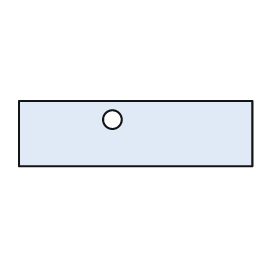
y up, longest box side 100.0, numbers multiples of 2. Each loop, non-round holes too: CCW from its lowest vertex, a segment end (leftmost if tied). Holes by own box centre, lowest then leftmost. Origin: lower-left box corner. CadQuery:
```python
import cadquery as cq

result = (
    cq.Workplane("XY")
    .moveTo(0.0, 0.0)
    .lineTo(100.0, 0.0)
    .lineTo(100.0, 28.0)
    .lineTo(0.0, 28.0)
    .close()
    .moveTo(40.0, 20.0)
    .circle(4.0)
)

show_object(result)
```